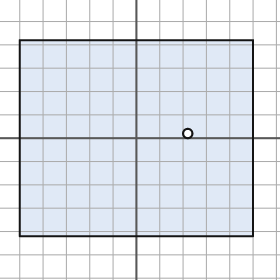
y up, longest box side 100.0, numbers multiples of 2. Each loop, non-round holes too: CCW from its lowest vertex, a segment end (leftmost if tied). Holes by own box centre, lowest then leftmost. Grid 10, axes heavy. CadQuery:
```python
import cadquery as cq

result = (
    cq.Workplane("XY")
    .moveTo(-50.0, -42.0)
    .lineTo(50.0, -42.0)
    .lineTo(50.0, 42.0)
    .lineTo(-50.0, 42.0)
    .close()
    .moveTo(22.0, 2.0)
    .circle(2.0)
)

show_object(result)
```